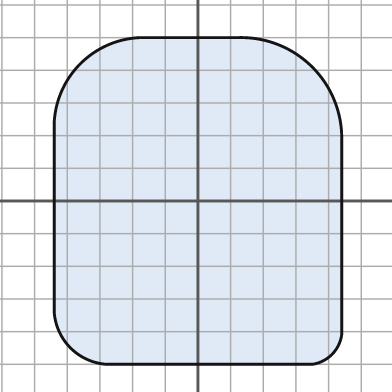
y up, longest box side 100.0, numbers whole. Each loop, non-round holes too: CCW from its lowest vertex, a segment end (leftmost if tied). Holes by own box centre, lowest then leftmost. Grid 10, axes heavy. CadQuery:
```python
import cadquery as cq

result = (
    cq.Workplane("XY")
    .moveTo(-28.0, -50.0)
    .lineTo(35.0, -50.0)
    .threePointArc((41.0, -47.0), (44.0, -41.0))
    .lineTo(44.0, 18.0)
    .threePointArc((35.0, 41.0), (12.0, 50.0))
    .lineTo(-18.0, 50.0)
    .threePointArc((-36.0, 42.0), (-44.0, 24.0))
    .lineTo(-44.0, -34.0)
    .threePointArc((-39.0, -45.0), (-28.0, -50.0))
    .close()
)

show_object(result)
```